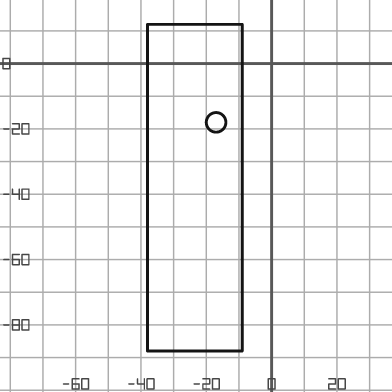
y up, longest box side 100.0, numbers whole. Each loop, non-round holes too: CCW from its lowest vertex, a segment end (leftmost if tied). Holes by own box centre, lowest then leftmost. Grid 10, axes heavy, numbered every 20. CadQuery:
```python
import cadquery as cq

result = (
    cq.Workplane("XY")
    .moveTo(-38.0, -88.0)
    .lineTo(-9.0, -88.0)
    .lineTo(-9.0, 12.0)
    .lineTo(-38.0, 12.0)
    .close()
    .moveTo(-17.0, -18.0)
    .circle(3.0)
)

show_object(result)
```